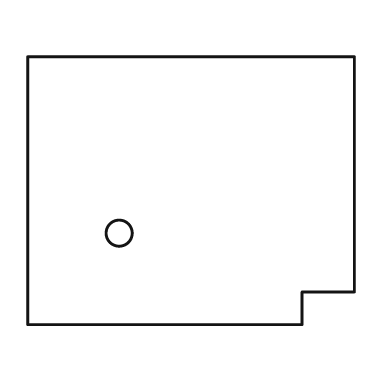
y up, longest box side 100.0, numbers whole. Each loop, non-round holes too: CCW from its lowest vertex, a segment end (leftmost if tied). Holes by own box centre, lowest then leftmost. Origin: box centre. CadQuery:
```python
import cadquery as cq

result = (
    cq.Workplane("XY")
    .moveTo(-50.0, -41.0)
    .lineTo(34.0, -41.0)
    .lineTo(34.0, -31.0)
    .lineTo(50.0, -31.0)
    .lineTo(50.0, 41.0)
    .lineTo(-50.0, 41.0)
    .close()
    .moveTo(-22.0, -13.0)
    .circle(4.0)
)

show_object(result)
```